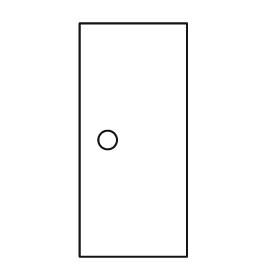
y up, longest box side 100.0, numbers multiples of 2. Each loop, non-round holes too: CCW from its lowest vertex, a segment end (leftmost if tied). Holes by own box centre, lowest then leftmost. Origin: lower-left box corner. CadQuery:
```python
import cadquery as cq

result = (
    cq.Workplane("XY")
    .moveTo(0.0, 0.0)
    .lineTo(46.0, 0.0)
    .lineTo(46.0, 100.0)
    .lineTo(0.0, 100.0)
    .close()
    .moveTo(12.0, 50.0)
    .circle(4.0)
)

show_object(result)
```